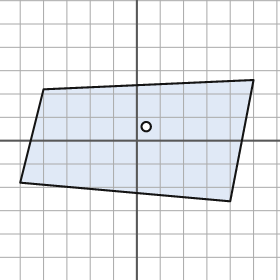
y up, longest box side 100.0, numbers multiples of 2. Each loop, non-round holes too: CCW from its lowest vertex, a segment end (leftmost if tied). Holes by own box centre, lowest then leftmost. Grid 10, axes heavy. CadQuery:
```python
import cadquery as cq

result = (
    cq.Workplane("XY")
    .moveTo(40.0, -26.0)
    .lineTo(50.0, 26.0)
    .lineTo(-40.0, 22.0)
    .lineTo(-50.0, -18.0)
    .close()
    .moveTo(4.0, 6.0)
    .circle(2.0)
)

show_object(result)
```